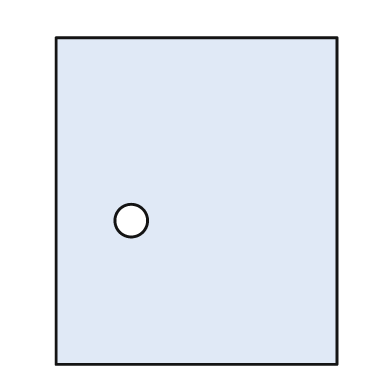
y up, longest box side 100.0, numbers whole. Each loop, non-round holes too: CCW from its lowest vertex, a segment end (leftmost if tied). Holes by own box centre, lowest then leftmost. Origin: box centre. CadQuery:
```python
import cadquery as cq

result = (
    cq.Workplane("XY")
    .moveTo(-43.0, -50.0)
    .lineTo(43.0, -50.0)
    .lineTo(43.0, 50.0)
    .lineTo(-43.0, 50.0)
    .close()
    .moveTo(-20.0, -6.0)
    .circle(5.0)
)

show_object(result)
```